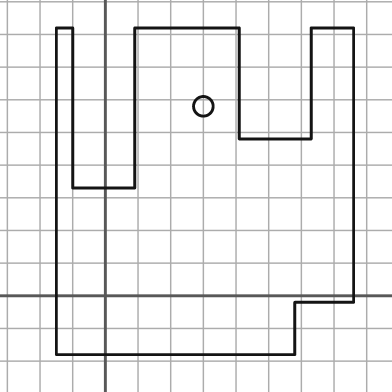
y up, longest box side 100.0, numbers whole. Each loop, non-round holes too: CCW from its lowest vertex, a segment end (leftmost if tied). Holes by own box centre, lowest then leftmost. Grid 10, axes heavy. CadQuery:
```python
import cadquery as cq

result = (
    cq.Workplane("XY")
    .moveTo(-15.0, -18.0)
    .lineTo(58.0, -18.0)
    .lineTo(58.0, -2.0)
    .lineTo(76.0, -2.0)
    .lineTo(76.0, 82.0)
    .lineTo(63.0, 82.0)
    .lineTo(63.0, 48.0)
    .lineTo(41.0, 48.0)
    .lineTo(41.0, 82.0)
    .lineTo(9.0, 82.0)
    .lineTo(9.0, 33.0)
    .lineTo(-10.0, 33.0)
    .lineTo(-10.0, 82.0)
    .lineTo(-15.0, 82.0)
    .close()
    .moveTo(30.0, 58.0)
    .circle(3.0)
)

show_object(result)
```